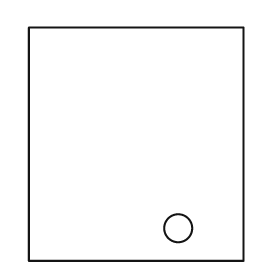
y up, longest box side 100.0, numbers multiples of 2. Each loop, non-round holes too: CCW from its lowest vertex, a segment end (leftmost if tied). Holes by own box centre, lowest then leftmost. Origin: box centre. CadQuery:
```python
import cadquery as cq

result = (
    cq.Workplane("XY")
    .moveTo(-46.0, -50.0)
    .lineTo(46.0, -50.0)
    .lineTo(46.0, 50.0)
    .lineTo(-46.0, 50.0)
    .close()
    .moveTo(18.0, -36.0)
    .circle(6.0)
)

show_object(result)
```